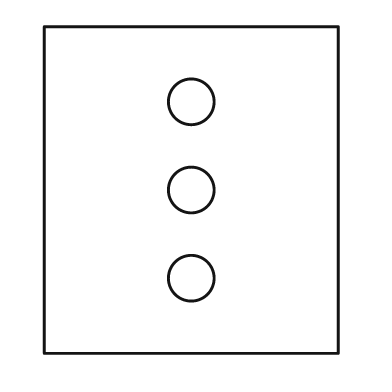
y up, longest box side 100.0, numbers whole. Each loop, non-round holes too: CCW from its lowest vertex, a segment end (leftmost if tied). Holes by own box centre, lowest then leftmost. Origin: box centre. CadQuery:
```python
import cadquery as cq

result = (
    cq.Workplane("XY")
    .moveTo(-45.0, -50.0)
    .lineTo(45.0, -50.0)
    .lineTo(45.0, 50.0)
    .lineTo(-45.0, 50.0)
    .close()
    .moveTo(0.0, -27.0)
    .circle(7.0)
    .moveTo(0.0, 0.0)
    .circle(7.0)
    .moveTo(0.0, 27.0)
    .circle(7.0)
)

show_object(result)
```